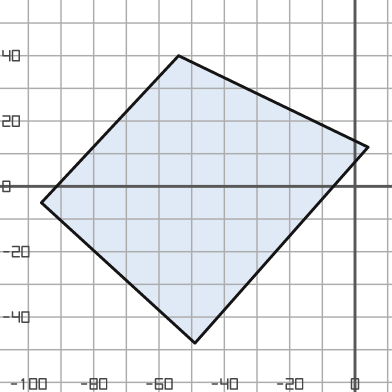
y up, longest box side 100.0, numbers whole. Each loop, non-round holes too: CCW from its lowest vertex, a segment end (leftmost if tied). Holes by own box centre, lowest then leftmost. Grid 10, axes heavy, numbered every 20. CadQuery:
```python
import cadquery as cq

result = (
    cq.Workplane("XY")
    .moveTo(-49.0, -48.0)
    .lineTo(4.0, 12.0)
    .lineTo(-54.0, 40.0)
    .lineTo(-96.0, -5.0)
    .close()
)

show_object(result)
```